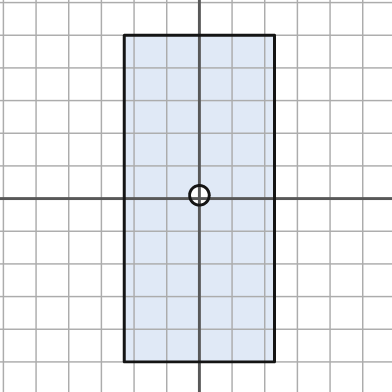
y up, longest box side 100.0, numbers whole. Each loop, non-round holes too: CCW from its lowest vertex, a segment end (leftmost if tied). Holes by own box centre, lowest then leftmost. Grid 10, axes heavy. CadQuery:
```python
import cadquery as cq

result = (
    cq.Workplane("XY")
    .moveTo(-23.0, -50.0)
    .lineTo(23.0, -50.0)
    .lineTo(23.0, 50.0)
    .lineTo(-23.0, 50.0)
    .close()
    .moveTo(0.0, 1.0)
    .circle(3.0)
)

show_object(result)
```